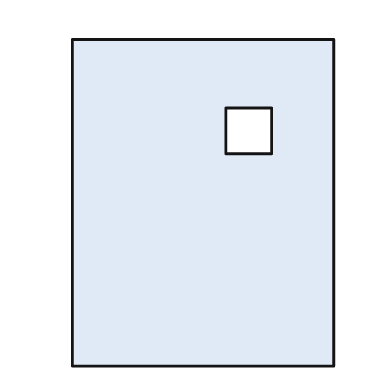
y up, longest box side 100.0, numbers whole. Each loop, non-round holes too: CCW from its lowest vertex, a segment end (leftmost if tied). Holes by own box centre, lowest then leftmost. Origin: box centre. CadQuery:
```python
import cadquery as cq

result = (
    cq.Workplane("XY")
    .moveTo(-40.0, -50.0)
    .lineTo(40.0, -50.0)
    .lineTo(40.0, 50.0)
    .lineTo(-40.0, 50.0)
    .close()
    .moveTo(7.0, 15.0)
    .lineTo(21.0, 15.0)
    .lineTo(21.0, 29.0)
    .lineTo(7.0, 29.0)
    .close()
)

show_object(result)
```